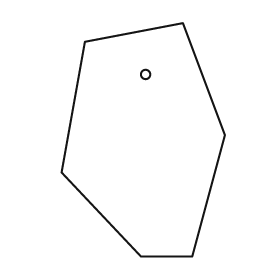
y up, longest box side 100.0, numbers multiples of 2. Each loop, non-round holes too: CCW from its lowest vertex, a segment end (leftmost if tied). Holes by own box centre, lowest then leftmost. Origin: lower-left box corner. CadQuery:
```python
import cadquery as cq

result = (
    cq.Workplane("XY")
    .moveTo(34.0, 0.0)
    .lineTo(56.0, 0.0)
    .lineTo(70.0, 52.0)
    .lineTo(52.0, 100.0)
    .lineTo(10.0, 92.0)
    .lineTo(0.0, 36.0)
    .close()
    .moveTo(36.0, 78.0)
    .circle(2.0)
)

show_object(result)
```